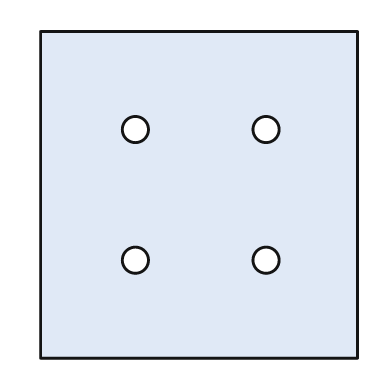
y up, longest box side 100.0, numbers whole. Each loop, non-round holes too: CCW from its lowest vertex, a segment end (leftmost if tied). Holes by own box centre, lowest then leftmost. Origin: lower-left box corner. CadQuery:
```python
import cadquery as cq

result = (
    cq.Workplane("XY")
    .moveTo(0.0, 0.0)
    .lineTo(97.0, 0.0)
    .lineTo(97.0, 100.0)
    .lineTo(0.0, 100.0)
    .close()
    .moveTo(29.0, 30.0)
    .circle(4.0)
    .moveTo(69.0, 30.0)
    .circle(4.0)
    .moveTo(29.0, 70.0)
    .circle(4.0)
    .moveTo(69.0, 70.0)
    .circle(4.0)
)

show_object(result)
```